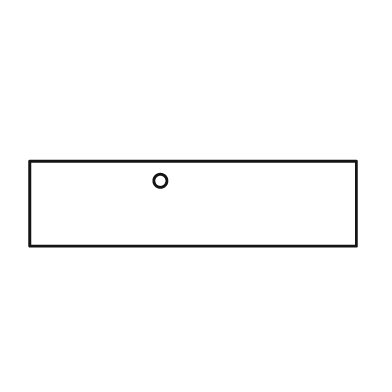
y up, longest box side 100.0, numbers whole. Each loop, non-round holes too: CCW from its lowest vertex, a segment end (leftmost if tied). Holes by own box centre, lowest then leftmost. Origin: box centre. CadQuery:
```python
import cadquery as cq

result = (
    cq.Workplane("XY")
    .moveTo(-50.0, -13.0)
    .lineTo(50.0, -13.0)
    .lineTo(50.0, 13.0)
    .lineTo(-50.0, 13.0)
    .close()
    .moveTo(-10.0, 7.0)
    .circle(2.0)
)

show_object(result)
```